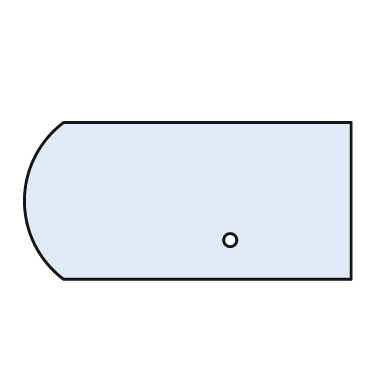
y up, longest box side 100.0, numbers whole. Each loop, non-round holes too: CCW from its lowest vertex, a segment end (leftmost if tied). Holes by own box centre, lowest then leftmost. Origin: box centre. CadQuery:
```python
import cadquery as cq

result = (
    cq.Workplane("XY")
    .moveTo(-38.0, -24.0)
    .lineTo(50.0, -24.0)
    .lineTo(50.0, 24.0)
    .lineTo(-38.0, 24.0)
    .threePointArc((-50.0, 0.0), (-38.0, -24.0))
    .close()
    .moveTo(13.0, -12.0)
    .circle(2.0)
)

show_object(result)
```